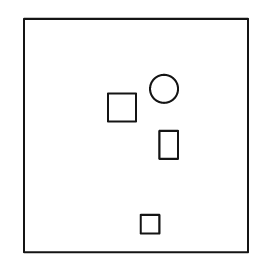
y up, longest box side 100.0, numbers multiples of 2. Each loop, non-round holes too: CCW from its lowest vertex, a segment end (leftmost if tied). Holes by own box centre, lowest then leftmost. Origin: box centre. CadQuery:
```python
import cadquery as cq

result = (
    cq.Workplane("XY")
    .moveTo(-48.0, -50.0)
    .lineTo(48.0, -50.0)
    .lineTo(48.0, 50.0)
    .lineTo(-48.0, 50.0)
    .close()
    .moveTo(2.0, -42.0)
    .lineTo(10.0, -42.0)
    .lineTo(10.0, -34.0)
    .lineTo(2.0, -34.0)
    .close()
    .moveTo(10.0, -10.0)
    .lineTo(18.0, -10.0)
    .lineTo(18.0, 2.0)
    .lineTo(10.0, 2.0)
    .close()
    .moveTo(-12.0, 6.0)
    .lineTo(0.0, 6.0)
    .lineTo(0.0, 18.0)
    .lineTo(-12.0, 18.0)
    .close()
    .moveTo(12.0, 20.0)
    .circle(6.0)
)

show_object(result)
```